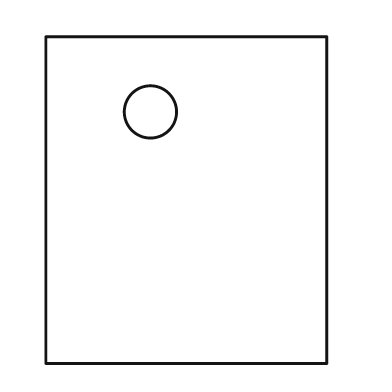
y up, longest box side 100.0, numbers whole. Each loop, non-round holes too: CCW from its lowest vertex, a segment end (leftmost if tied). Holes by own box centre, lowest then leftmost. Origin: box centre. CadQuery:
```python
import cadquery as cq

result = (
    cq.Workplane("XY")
    .moveTo(-43.0, -50.0)
    .lineTo(43.0, -50.0)
    .lineTo(43.0, 50.0)
    .lineTo(-43.0, 50.0)
    .close()
    .moveTo(-11.0, 27.0)
    .circle(8.0)
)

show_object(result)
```